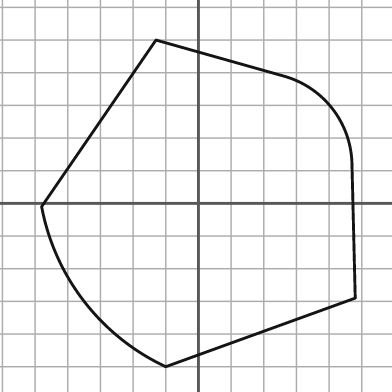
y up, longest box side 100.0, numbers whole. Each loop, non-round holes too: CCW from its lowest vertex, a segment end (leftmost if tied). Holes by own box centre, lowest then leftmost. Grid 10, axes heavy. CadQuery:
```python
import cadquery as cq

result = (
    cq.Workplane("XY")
    .moveTo(-10.0, -50.0)
    .lineTo(48.0, -29.0)
    .lineTo(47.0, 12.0)
    .threePointArc((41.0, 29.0), (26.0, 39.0))
    .lineTo(-13.0, 50.0)
    .lineTo(-48.0, -1.0)
    .threePointArc((-35.0, -30.0), (-10.0, -50.0))
    .close()
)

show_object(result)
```